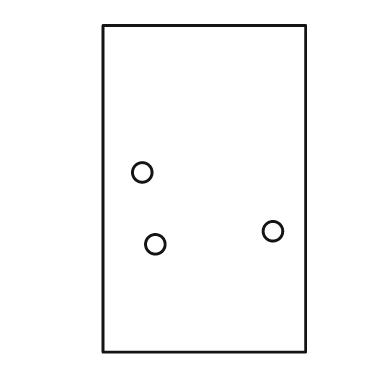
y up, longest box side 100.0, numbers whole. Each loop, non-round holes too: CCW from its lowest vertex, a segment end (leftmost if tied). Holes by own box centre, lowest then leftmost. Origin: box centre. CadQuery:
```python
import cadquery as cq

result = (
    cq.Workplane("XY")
    .moveTo(-31.0, -50.0)
    .lineTo(31.0, -50.0)
    .lineTo(31.0, 50.0)
    .lineTo(-31.0, 50.0)
    .close()
    .moveTo(-15.0, -17.0)
    .circle(3.0)
    .moveTo(21.0, -13.0)
    .circle(3.0)
    .moveTo(-19.0, 5.0)
    .circle(3.0)
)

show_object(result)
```